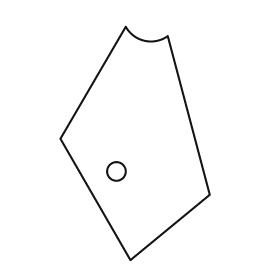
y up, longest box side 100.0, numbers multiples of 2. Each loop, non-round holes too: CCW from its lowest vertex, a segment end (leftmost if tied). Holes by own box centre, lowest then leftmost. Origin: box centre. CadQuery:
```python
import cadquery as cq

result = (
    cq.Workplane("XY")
    .moveTo(-2.0, -50.0)
    .lineTo(32.0, -22.0)
    .lineTo(14.0, 46.0)
    .threePointArc((4.0, 44.0), (-4.0, 50.0))
    .lineTo(-32.0, 2.0)
    .close()
    .moveTo(-8.0, -12.0)
    .circle(4.0)
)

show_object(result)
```